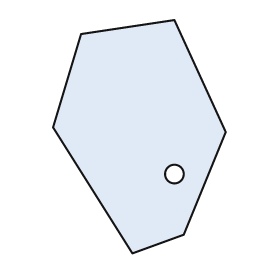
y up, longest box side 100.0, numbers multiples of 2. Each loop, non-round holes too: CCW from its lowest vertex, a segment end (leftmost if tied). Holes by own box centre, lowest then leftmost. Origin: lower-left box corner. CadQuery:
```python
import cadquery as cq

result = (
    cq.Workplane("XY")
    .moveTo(34.0, 0.0)
    .lineTo(56.0, 8.0)
    .lineTo(74.0, 52.0)
    .lineTo(52.0, 100.0)
    .lineTo(12.0, 94.0)
    .lineTo(0.0, 54.0)
    .close()
    .moveTo(52.0, 34.0)
    .circle(4.0)
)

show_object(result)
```